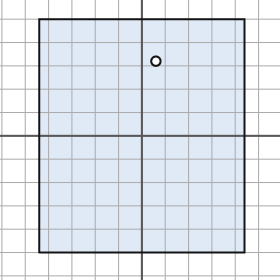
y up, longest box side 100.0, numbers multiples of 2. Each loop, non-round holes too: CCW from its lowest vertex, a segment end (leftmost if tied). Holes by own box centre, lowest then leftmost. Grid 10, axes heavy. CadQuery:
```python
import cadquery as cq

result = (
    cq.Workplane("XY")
    .moveTo(-44.0, -50.0)
    .lineTo(44.0, -50.0)
    .lineTo(44.0, 50.0)
    .lineTo(-44.0, 50.0)
    .close()
    .moveTo(6.0, 32.0)
    .circle(2.0)
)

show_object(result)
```